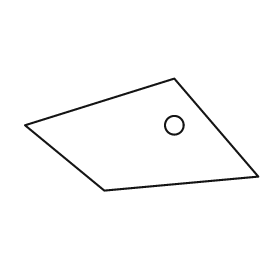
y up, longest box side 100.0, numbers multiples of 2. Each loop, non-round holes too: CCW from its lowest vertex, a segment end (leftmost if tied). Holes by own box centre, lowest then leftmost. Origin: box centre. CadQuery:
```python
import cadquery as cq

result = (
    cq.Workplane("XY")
    .moveTo(-16.0, -24.0)
    .lineTo(50.0, -18.0)
    .lineTo(14.0, 24.0)
    .lineTo(-50.0, 4.0)
    .close()
    .moveTo(14.0, 4.0)
    .circle(4.0)
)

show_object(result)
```